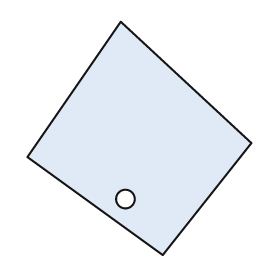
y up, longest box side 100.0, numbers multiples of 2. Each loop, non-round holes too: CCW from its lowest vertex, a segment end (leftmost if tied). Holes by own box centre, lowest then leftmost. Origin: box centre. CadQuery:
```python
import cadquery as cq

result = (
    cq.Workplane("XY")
    .moveTo(10.0, -50.0)
    .lineTo(48.0, -2.0)
    .lineTo(-8.0, 50.0)
    .lineTo(-48.0, -8.0)
    .close()
    .moveTo(-6.0, -26.0)
    .circle(4.0)
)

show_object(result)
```